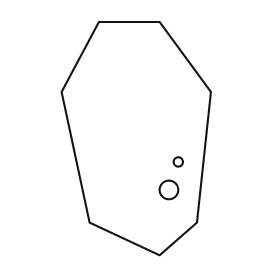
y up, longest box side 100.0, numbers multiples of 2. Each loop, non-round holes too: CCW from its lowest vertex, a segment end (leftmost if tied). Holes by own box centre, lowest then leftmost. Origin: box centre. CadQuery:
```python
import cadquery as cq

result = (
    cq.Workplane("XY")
    .moveTo(10.0, -50.0)
    .lineTo(26.0, -36.0)
    .lineTo(32.0, 20.0)
    .lineTo(10.0, 50.0)
    .lineTo(-16.0, 50.0)
    .lineTo(-32.0, 20.0)
    .lineTo(-20.0, -36.0)
    .close()
    .moveTo(14.0, -22.0)
    .circle(4.0)
    .moveTo(18.0, -10.0)
    .circle(2.0)
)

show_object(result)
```